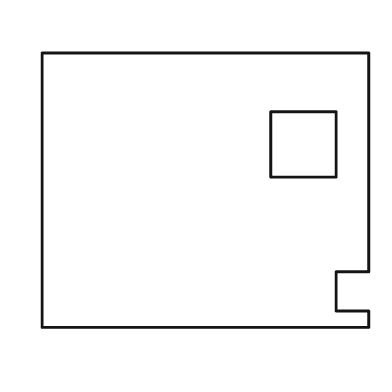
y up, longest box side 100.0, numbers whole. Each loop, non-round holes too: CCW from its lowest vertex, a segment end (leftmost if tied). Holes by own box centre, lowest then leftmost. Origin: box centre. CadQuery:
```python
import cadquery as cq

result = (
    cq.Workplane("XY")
    .moveTo(-50.0, -42.0)
    .lineTo(50.0, -42.0)
    .lineTo(50.0, -37.0)
    .lineTo(40.0, -37.0)
    .lineTo(40.0, -25.0)
    .lineTo(50.0, -25.0)
    .lineTo(50.0, 42.0)
    .lineTo(-50.0, 42.0)
    .close()
    .moveTo(20.0, 4.0)
    .lineTo(40.0, 4.0)
    .lineTo(40.0, 24.0)
    .lineTo(20.0, 24.0)
    .close()
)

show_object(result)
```